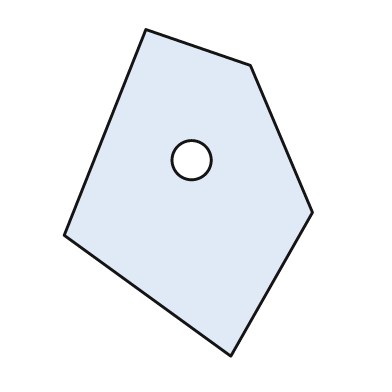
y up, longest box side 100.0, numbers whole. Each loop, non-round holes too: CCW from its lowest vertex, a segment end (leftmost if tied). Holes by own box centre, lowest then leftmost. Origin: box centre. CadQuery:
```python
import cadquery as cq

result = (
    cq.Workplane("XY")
    .moveTo(13.0, -50.0)
    .lineTo(38.0, -6.0)
    .lineTo(19.0, 39.0)
    .lineTo(-13.0, 50.0)
    .lineTo(-38.0, -13.0)
    .close()
    .moveTo(1.0, 10.0)
    .circle(6.0)
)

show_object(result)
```